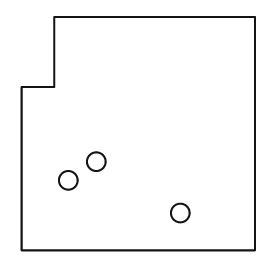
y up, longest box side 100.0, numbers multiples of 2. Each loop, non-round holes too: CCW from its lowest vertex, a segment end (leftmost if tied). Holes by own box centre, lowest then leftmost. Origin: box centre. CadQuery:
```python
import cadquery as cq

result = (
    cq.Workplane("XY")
    .moveTo(-50.0, -50.0)
    .lineTo(50.0, -50.0)
    .lineTo(50.0, 50.0)
    .lineTo(-36.0, 50.0)
    .lineTo(-36.0, 20.0)
    .lineTo(-50.0, 20.0)
    .close()
    .moveTo(18.0, -34.0)
    .circle(4.0)
    .moveTo(-30.0, -20.0)
    .circle(4.0)
    .moveTo(-18.0, -12.0)
    .circle(4.0)
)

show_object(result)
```